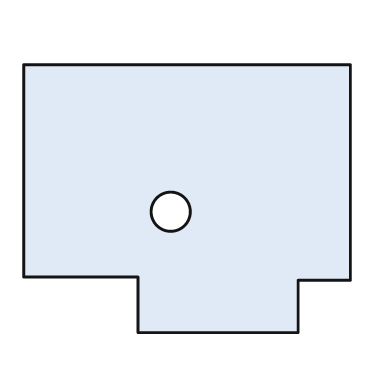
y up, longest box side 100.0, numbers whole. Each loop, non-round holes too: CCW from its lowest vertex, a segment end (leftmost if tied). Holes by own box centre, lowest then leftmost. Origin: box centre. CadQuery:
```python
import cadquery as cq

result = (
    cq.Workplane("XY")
    .moveTo(-15.0, -41.0)
    .lineTo(34.0, -41.0)
    .lineTo(34.0, -25.0)
    .lineTo(50.0, -25.0)
    .lineTo(50.0, 41.0)
    .lineTo(-50.0, 41.0)
    .lineTo(-50.0, -24.0)
    .lineTo(-15.0, -24.0)
    .close()
    .moveTo(-5.0, -4.0)
    .circle(6.0)
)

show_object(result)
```